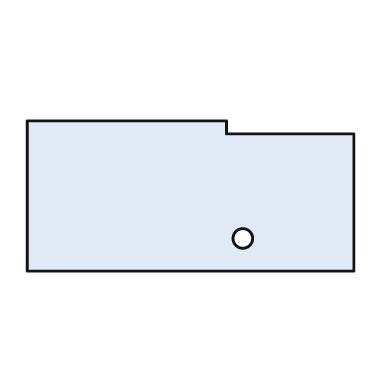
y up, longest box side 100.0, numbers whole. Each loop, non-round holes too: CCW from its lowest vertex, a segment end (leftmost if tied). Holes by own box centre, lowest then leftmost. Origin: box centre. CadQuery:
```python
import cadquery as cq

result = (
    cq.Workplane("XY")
    .moveTo(-50.0, -23.0)
    .lineTo(50.0, -23.0)
    .lineTo(50.0, 19.0)
    .lineTo(11.0, 19.0)
    .lineTo(11.0, 23.0)
    .lineTo(-50.0, 23.0)
    .close()
    .moveTo(16.0, -13.0)
    .circle(3.0)
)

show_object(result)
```